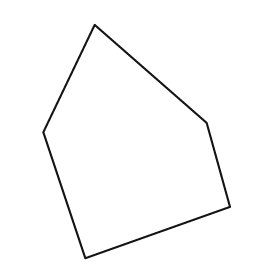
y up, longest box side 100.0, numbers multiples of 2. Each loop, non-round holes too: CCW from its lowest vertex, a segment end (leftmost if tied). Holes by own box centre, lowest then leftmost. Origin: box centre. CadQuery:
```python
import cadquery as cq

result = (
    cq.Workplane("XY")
    .moveTo(-22.0, -50.0)
    .lineTo(40.0, -28.0)
    .lineTo(30.0, 8.0)
    .lineTo(-18.0, 50.0)
    .lineTo(-40.0, 4.0)
    .close()
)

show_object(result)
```